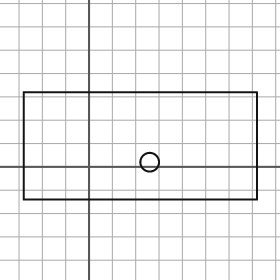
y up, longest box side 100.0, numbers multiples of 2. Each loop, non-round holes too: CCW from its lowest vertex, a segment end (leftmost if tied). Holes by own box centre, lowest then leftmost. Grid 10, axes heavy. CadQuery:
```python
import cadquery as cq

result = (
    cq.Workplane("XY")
    .moveTo(-28.0, -14.0)
    .lineTo(72.0, -14.0)
    .lineTo(72.0, 32.0)
    .lineTo(-28.0, 32.0)
    .close()
    .moveTo(26.0, 2.0)
    .circle(4.0)
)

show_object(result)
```